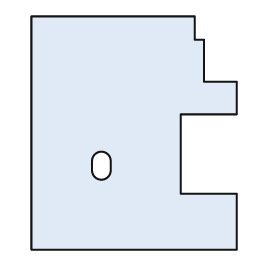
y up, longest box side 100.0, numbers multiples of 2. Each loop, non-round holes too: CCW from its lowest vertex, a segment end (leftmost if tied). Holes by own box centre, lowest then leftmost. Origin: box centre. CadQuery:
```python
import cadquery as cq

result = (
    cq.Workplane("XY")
    .moveTo(-44.0, -50.0)
    .lineTo(44.0, -50.0)
    .lineTo(44.0, -26.0)
    .lineTo(20.0, -26.0)
    .lineTo(20.0, 8.0)
    .lineTo(44.0, 8.0)
    .lineTo(44.0, 22.0)
    .lineTo(30.0, 22.0)
    .lineTo(30.0, 40.0)
    .lineTo(26.0, 40.0)
    .lineTo(26.0, 50.0)
    .lineTo(-44.0, 50.0)
    .close()
    .moveTo(-18.0, -16.0)
    .threePointArc((-14.0, -20.0), (-10.0, -16.0))
    .lineTo(-10.0, -12.0)
    .threePointArc((-14.0, -8.0), (-18.0, -12.0))
    .close()
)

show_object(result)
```